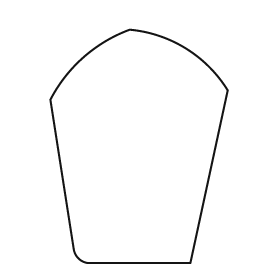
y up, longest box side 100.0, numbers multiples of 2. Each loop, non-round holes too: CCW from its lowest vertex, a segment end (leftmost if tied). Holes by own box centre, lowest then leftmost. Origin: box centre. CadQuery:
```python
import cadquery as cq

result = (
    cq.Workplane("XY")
    .moveTo(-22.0, -50.0)
    .lineTo(22.0, -50.0)
    .lineTo(38.0, 24.0)
    .threePointArc((20.0, 42.0), (-4.0, 50.0))
    .threePointArc((-24.0, 38.0), (-38.0, 20.0))
    .lineTo(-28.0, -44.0)
    .threePointArc((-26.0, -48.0), (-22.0, -50.0))
    .close()
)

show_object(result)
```